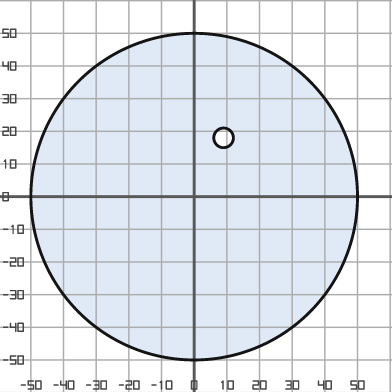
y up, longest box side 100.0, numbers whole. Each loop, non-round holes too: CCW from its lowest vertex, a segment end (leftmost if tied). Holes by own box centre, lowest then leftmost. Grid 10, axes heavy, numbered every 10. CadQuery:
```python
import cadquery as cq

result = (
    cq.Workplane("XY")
    .moveTo(0.0, 0.0)
    .circle(50.0)
    .moveTo(9.0, 18.0)
    .circle(3.0)
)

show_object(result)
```